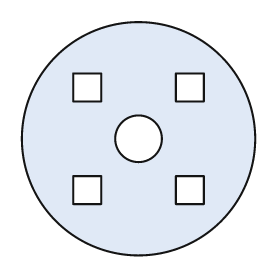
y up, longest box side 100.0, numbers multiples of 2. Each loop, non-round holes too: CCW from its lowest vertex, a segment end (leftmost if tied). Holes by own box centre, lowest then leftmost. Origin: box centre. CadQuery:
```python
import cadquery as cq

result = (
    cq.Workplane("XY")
    .moveTo(0.0, 0.0)
    .circle(50.0)
    .moveTo(-28.0, -28.0)
    .lineTo(-16.0, -28.0)
    .lineTo(-16.0, -16.0)
    .lineTo(-28.0, -16.0)
    .close()
    .moveTo(16.0, -28.0)
    .lineTo(28.0, -28.0)
    .lineTo(28.0, -16.0)
    .lineTo(16.0, -16.0)
    .close()
    .moveTo(0.0, 0.0)
    .circle(10.0)
    .moveTo(-28.0, 16.0)
    .lineTo(-16.0, 16.0)
    .lineTo(-16.0, 28.0)
    .lineTo(-28.0, 28.0)
    .close()
    .moveTo(16.0, 16.0)
    .lineTo(28.0, 16.0)
    .lineTo(28.0, 28.0)
    .lineTo(16.0, 28.0)
    .close()
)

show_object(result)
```